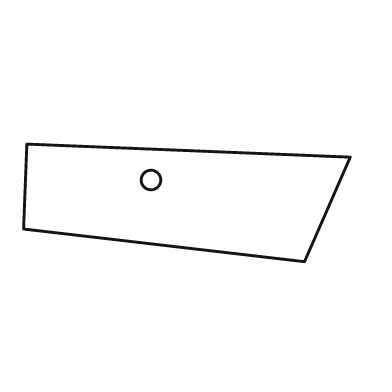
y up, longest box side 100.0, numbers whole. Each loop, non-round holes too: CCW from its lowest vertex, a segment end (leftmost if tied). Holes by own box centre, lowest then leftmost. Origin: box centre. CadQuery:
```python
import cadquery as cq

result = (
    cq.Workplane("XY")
    .moveTo(36.0, -18.0)
    .lineTo(50.0, 14.0)
    .lineTo(-49.0, 18.0)
    .lineTo(-50.0, -8.0)
    .close()
    .moveTo(-11.0, 7.0)
    .circle(3.0)
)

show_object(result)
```